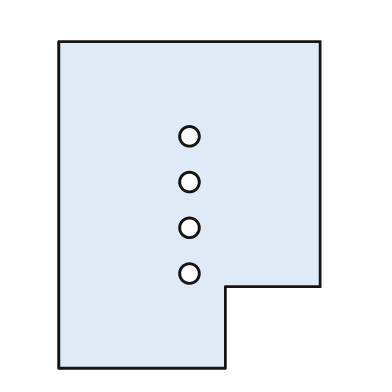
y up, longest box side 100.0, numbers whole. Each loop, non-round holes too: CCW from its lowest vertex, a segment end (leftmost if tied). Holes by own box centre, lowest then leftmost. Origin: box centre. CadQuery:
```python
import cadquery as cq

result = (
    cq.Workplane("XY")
    .moveTo(-40.0, -50.0)
    .lineTo(11.0, -50.0)
    .lineTo(11.0, -25.0)
    .lineTo(40.0, -25.0)
    .lineTo(40.0, 50.0)
    .lineTo(-40.0, 50.0)
    .close()
    .moveTo(0.0, -21.0)
    .circle(3.0)
    .moveTo(0.0, -7.0)
    .circle(3.0)
    .moveTo(0.0, 7.0)
    .circle(3.0)
    .moveTo(0.0, 21.0)
    .circle(3.0)
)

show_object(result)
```